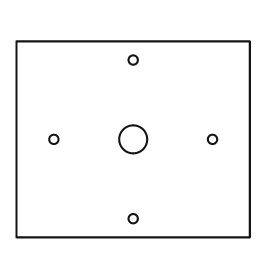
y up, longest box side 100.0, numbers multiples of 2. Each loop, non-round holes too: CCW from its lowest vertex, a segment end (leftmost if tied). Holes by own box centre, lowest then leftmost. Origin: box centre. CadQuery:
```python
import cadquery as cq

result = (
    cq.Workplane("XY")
    .moveTo(-50.0, -42.0)
    .lineTo(50.0, -42.0)
    .lineTo(50.0, 42.0)
    .lineTo(-50.0, 42.0)
    .close()
    .moveTo(0.0, -34.0)
    .circle(2.0)
    .moveTo(-34.0, 0.0)
    .circle(2.0)
    .moveTo(0.0, 0.0)
    .circle(6.0)
    .moveTo(34.0, 0.0)
    .circle(2.0)
    .moveTo(0.0, 34.0)
    .circle(2.0)
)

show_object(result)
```